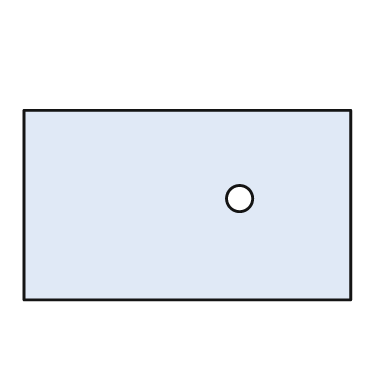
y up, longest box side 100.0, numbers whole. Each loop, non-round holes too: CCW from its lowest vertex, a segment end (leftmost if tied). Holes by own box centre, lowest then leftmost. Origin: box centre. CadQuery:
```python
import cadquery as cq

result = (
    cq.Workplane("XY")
    .moveTo(-50.0, -29.0)
    .lineTo(50.0, -29.0)
    .lineTo(50.0, 29.0)
    .lineTo(-50.0, 29.0)
    .close()
    .moveTo(16.0, 2.0)
    .circle(4.0)
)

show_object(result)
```